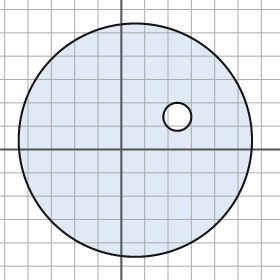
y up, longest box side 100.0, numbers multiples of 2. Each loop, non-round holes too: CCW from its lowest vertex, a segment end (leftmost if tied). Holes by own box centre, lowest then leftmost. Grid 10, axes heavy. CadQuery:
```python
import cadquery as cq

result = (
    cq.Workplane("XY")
    .moveTo(6.0, 4.0)
    .circle(50.0)
    .moveTo(24.0, 14.0)
    .circle(6.0)
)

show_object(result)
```